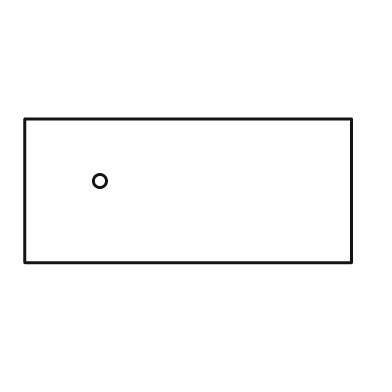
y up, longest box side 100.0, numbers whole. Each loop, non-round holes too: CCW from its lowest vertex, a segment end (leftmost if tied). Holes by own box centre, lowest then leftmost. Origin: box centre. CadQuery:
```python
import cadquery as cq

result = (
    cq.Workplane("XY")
    .moveTo(-50.0, -22.0)
    .lineTo(50.0, -22.0)
    .lineTo(50.0, 22.0)
    .lineTo(-50.0, 22.0)
    .close()
    .moveTo(-27.0, 3.0)
    .circle(2.0)
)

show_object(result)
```